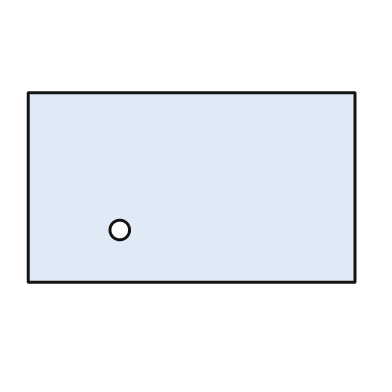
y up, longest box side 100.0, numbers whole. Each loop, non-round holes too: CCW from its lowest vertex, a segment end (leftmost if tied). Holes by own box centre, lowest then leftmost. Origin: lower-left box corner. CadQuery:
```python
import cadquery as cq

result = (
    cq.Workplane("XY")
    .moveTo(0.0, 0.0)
    .lineTo(100.0, 0.0)
    .lineTo(100.0, 58.0)
    .lineTo(0.0, 58.0)
    .close()
    .moveTo(28.0, 16.0)
    .circle(3.0)
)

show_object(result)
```